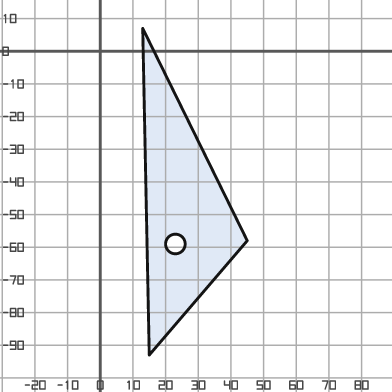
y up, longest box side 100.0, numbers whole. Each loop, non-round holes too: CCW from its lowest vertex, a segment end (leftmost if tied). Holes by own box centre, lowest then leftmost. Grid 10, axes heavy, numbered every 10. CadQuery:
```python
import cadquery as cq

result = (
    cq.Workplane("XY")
    .moveTo(15.0, -93.0)
    .lineTo(45.0, -58.0)
    .lineTo(13.0, 7.0)
    .close()
    .moveTo(23.0, -59.0)
    .circle(3.0)
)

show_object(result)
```